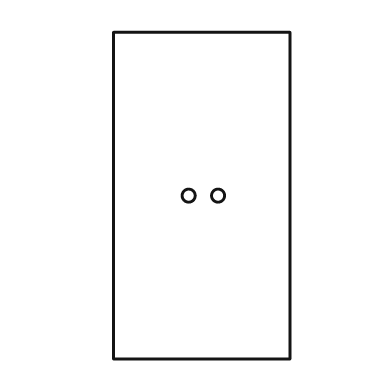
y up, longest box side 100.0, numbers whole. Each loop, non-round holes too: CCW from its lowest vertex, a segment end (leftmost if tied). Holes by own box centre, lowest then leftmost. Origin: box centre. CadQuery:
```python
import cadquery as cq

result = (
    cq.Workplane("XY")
    .moveTo(-27.0, -50.0)
    .lineTo(27.0, -50.0)
    .lineTo(27.0, 50.0)
    .lineTo(-27.0, 50.0)
    .close()
    .moveTo(-4.0, 0.0)
    .circle(2.0)
    .moveTo(5.0, 0.0)
    .circle(2.0)
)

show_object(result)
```